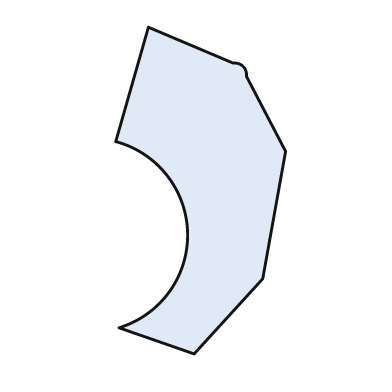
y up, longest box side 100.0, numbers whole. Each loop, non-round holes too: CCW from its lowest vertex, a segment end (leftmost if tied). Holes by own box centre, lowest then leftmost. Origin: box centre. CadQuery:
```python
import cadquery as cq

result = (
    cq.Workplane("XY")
    .moveTo(-2.0, -50.0)
    .lineTo(19.0, -27.0)
    .lineTo(26.0, 12.0)
    .lineTo(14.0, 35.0)
    .threePointArc((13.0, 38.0), (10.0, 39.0))
    .lineTo(-16.0, 50.0)
    .lineTo(-26.0, 15.0)
    .threePointArc((-4.0, -13.0), (-25.0, -42.0))
    .close()
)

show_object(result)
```